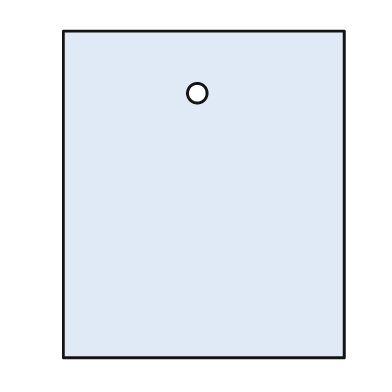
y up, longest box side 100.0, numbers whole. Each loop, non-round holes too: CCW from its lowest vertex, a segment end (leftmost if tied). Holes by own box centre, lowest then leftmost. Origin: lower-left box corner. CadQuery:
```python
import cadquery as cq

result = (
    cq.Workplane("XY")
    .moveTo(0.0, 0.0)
    .lineTo(86.0, 0.0)
    .lineTo(86.0, 100.0)
    .lineTo(0.0, 100.0)
    .close()
    .moveTo(41.0, 81.0)
    .circle(3.0)
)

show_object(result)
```